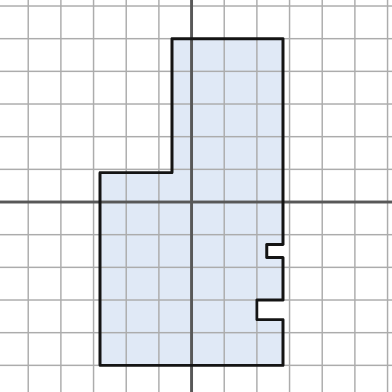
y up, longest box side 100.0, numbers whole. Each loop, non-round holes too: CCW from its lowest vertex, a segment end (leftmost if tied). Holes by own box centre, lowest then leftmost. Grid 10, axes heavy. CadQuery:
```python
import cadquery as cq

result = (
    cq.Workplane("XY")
    .moveTo(-28.0, -50.0)
    .lineTo(28.0, -50.0)
    .lineTo(28.0, -36.0)
    .lineTo(20.0, -36.0)
    .lineTo(20.0, -30.0)
    .lineTo(28.0, -30.0)
    .lineTo(28.0, -17.0)
    .lineTo(23.0, -17.0)
    .lineTo(23.0, -13.0)
    .lineTo(28.0, -13.0)
    .lineTo(28.0, 50.0)
    .lineTo(-6.0, 50.0)
    .lineTo(-6.0, 9.0)
    .lineTo(-28.0, 9.0)
    .close()
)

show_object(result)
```